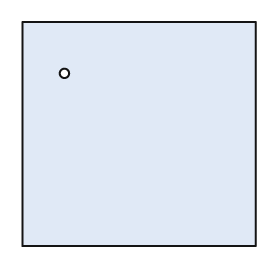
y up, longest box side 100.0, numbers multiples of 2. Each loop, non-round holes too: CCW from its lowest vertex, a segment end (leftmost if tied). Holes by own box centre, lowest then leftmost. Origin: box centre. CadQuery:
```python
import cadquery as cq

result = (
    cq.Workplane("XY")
    .moveTo(-50.0, -48.0)
    .lineTo(50.0, -48.0)
    .lineTo(50.0, 48.0)
    .lineTo(-50.0, 48.0)
    .close()
    .moveTo(-32.0, 26.0)
    .circle(2.0)
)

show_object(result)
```